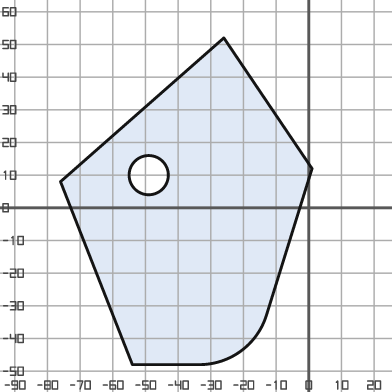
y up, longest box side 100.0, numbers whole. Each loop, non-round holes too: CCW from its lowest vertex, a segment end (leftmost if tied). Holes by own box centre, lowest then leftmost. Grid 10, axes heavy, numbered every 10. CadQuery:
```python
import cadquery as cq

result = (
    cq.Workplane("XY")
    .moveTo(-54.0, -48.0)
    .lineTo(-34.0, -48.0)
    .threePointArc((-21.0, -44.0), (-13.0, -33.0))
    .lineTo(1.0, 12.0)
    .lineTo(-26.0, 52.0)
    .lineTo(-76.0, 8.0)
    .close()
    .moveTo(-49.0, 10.0)
    .circle(6.0)
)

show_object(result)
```